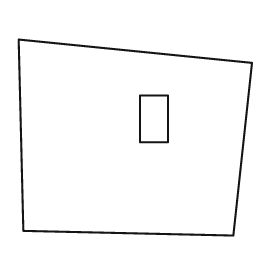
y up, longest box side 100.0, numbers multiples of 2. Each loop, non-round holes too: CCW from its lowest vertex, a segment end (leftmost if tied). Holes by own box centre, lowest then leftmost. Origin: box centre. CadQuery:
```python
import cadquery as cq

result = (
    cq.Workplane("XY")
    .moveTo(42.0, -42.0)
    .lineTo(50.0, 32.0)
    .lineTo(-50.0, 42.0)
    .lineTo(-48.0, -40.0)
    .close()
    .moveTo(2.0, -2.0)
    .lineTo(14.0, -2.0)
    .lineTo(14.0, 18.0)
    .lineTo(2.0, 18.0)
    .close()
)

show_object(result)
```